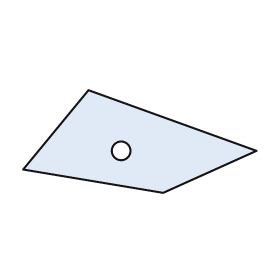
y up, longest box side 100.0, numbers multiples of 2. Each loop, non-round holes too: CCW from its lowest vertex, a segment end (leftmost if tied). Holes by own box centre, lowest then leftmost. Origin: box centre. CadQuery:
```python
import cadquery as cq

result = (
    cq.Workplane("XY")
    .moveTo(10.0, -22.0)
    .lineTo(50.0, -4.0)
    .lineTo(-22.0, 22.0)
    .lineTo(-50.0, -12.0)
    .close()
    .moveTo(-8.0, -4.0)
    .circle(4.0)
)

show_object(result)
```